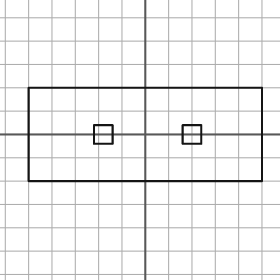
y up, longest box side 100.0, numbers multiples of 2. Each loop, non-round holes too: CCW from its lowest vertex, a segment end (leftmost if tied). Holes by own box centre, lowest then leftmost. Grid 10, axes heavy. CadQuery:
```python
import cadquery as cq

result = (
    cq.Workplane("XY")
    .moveTo(-50.0, -20.0)
    .lineTo(50.0, -20.0)
    .lineTo(50.0, 20.0)
    .lineTo(-50.0, 20.0)
    .close()
    .moveTo(-22.0, -4.0)
    .lineTo(-14.0, -4.0)
    .lineTo(-14.0, 4.0)
    .lineTo(-22.0, 4.0)
    .close()
    .moveTo(16.0, -4.0)
    .lineTo(24.0, -4.0)
    .lineTo(24.0, 4.0)
    .lineTo(16.0, 4.0)
    .close()
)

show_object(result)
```